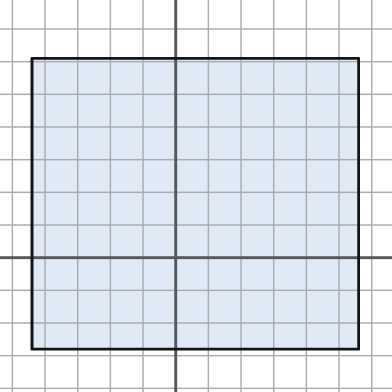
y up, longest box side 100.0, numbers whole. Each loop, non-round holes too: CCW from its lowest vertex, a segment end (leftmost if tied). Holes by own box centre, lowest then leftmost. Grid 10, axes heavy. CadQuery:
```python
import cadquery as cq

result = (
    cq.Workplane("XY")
    .moveTo(-44.0, -28.0)
    .lineTo(56.0, -28.0)
    .lineTo(56.0, 61.0)
    .lineTo(-44.0, 61.0)
    .close()
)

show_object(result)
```